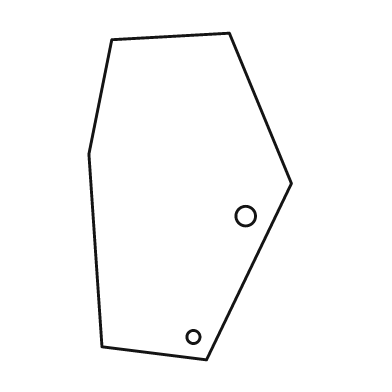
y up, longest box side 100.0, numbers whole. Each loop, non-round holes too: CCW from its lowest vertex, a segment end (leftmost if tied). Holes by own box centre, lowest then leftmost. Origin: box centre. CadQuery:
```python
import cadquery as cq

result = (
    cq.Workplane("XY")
    .moveTo(5.0, -50.0)
    .lineTo(31.0, 4.0)
    .lineTo(12.0, 50.0)
    .lineTo(-24.0, 48.0)
    .lineTo(-31.0, 13.0)
    .lineTo(-27.0, -46.0)
    .close()
    .moveTo(1.0, -43.0)
    .circle(2.0)
    .moveTo(17.0, -6.0)
    .circle(3.0)
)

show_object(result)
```